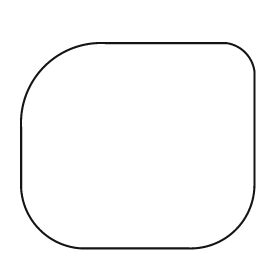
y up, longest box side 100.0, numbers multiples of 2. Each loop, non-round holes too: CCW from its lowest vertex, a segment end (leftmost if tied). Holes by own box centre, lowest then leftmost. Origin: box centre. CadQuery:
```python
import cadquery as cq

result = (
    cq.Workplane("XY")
    .moveTo(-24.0, -44.0)
    .lineTo(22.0, -44.0)
    .threePointArc((42.0, -36.0), (50.0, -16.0))
    .lineTo(50.0, 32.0)
    .threePointArc((46.0, 40.0), (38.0, 44.0))
    .lineTo(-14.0, 44.0)
    .threePointArc((-40.0, 34.0), (-50.0, 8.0))
    .lineTo(-50.0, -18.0)
    .threePointArc((-42.0, -36.0), (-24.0, -44.0))
    .close()
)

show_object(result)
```